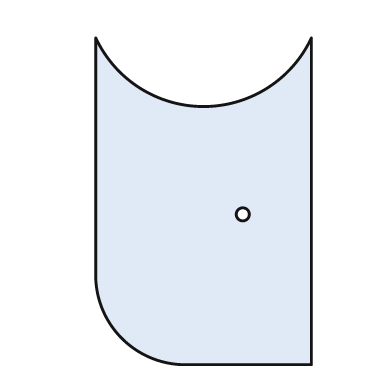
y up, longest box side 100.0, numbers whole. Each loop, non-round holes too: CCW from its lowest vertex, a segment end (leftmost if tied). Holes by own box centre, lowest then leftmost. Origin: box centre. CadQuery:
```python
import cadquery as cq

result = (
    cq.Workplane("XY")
    .moveTo(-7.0, -50.0)
    .lineTo(33.0, -50.0)
    .lineTo(33.0, 50.0)
    .threePointArc((0.0, 29.0), (-33.0, 50.0))
    .lineTo(-33.0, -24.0)
    .threePointArc((-25.0, -42.0), (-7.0, -50.0))
    .close()
    .moveTo(12.0, -4.0)
    .circle(2.0)
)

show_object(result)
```